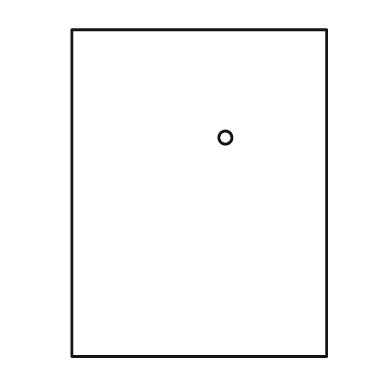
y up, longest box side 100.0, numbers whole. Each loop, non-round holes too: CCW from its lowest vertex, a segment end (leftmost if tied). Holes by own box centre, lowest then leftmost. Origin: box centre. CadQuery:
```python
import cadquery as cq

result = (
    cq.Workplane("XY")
    .moveTo(-39.0, -50.0)
    .lineTo(39.0, -50.0)
    .lineTo(39.0, 50.0)
    .lineTo(-39.0, 50.0)
    .close()
    .moveTo(8.0, 17.0)
    .circle(2.0)
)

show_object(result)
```